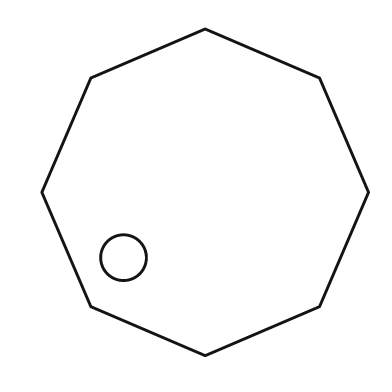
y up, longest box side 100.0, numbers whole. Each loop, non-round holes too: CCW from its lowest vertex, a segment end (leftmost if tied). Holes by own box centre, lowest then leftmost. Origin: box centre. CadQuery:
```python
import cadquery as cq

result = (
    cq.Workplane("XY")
    .moveTo(0.0, -50.0)
    .lineTo(35.0, -35.0)
    .lineTo(50.0, 0.0)
    .lineTo(35.0, 35.0)
    .lineTo(0.0, 50.0)
    .lineTo(-35.0, 35.0)
    .lineTo(-50.0, 0.0)
    .lineTo(-35.0, -35.0)
    .close()
    .moveTo(-25.0, -20.0)
    .circle(7.0)
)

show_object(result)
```